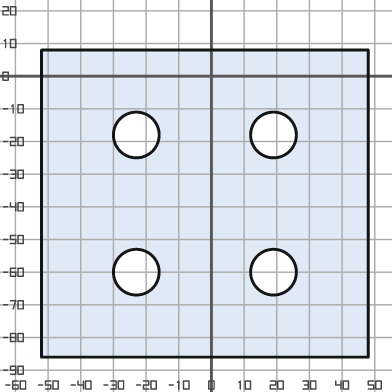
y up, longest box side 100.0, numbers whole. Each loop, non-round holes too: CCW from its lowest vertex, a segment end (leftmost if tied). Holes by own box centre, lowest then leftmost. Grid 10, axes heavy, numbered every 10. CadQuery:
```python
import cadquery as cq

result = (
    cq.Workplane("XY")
    .moveTo(-52.0, -86.0)
    .lineTo(48.0, -86.0)
    .lineTo(48.0, 8.0)
    .lineTo(-52.0, 8.0)
    .close()
    .moveTo(-23.0, -60.0)
    .circle(7.0)
    .moveTo(19.0, -60.0)
    .circle(7.0)
    .moveTo(-23.0, -18.0)
    .circle(7.0)
    .moveTo(19.0, -18.0)
    .circle(7.0)
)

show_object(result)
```